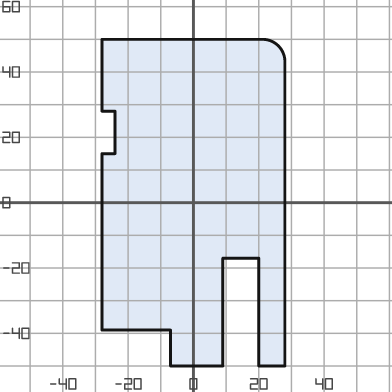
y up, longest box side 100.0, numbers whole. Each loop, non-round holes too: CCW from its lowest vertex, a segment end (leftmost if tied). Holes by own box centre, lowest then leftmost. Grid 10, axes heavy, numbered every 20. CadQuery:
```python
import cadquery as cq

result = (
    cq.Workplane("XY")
    .moveTo(-7.0, -50.0)
    .lineTo(9.0, -50.0)
    .lineTo(9.0, -17.0)
    .lineTo(20.0, -17.0)
    .lineTo(20.0, -50.0)
    .lineTo(28.0, -50.0)
    .lineTo(28.0, 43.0)
    .threePointArc((26.0, 48.0), (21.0, 50.0))
    .lineTo(-28.0, 50.0)
    .lineTo(-28.0, 28.0)
    .lineTo(-24.0, 28.0)
    .lineTo(-24.0, 15.0)
    .lineTo(-28.0, 15.0)
    .lineTo(-28.0, -39.0)
    .lineTo(-7.0, -39.0)
    .close()
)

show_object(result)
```